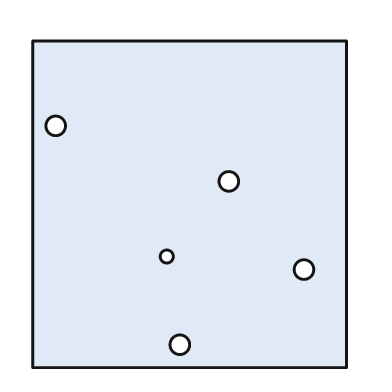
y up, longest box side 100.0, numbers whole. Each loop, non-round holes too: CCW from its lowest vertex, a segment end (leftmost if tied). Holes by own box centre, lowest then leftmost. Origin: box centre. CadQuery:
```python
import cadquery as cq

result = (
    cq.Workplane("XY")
    .moveTo(-48.0, -50.0)
    .lineTo(48.0, -50.0)
    .lineTo(48.0, 50.0)
    .lineTo(-48.0, 50.0)
    .close()
    .moveTo(-3.0, -43.0)
    .circle(3.0)
    .moveTo(35.0, -20.0)
    .circle(3.0)
    .moveTo(-7.0, -16.0)
    .circle(2.0)
    .moveTo(12.0, 7.0)
    .circle(3.0)
    .moveTo(-41.0, 24.0)
    .circle(3.0)
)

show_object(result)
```